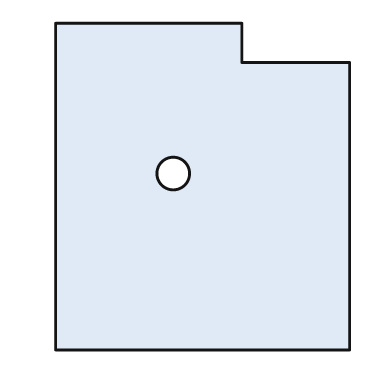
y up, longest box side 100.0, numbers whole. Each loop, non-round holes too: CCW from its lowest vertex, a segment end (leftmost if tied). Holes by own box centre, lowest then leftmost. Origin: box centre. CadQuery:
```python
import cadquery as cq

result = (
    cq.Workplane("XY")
    .moveTo(-45.0, -50.0)
    .lineTo(45.0, -50.0)
    .lineTo(45.0, 38.0)
    .lineTo(12.0, 38.0)
    .lineTo(12.0, 50.0)
    .lineTo(-45.0, 50.0)
    .close()
    .moveTo(-9.0, 4.0)
    .circle(5.0)
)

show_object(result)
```